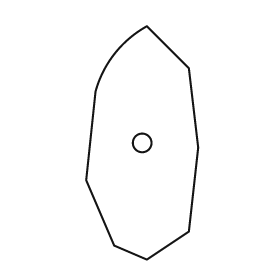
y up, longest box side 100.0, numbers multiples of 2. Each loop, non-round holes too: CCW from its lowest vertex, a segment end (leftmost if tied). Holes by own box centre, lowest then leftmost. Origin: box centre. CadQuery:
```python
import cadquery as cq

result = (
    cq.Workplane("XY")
    .moveTo(2.0, -50.0)
    .lineTo(20.0, -38.0)
    .lineTo(24.0, -2.0)
    .lineTo(20.0, 32.0)
    .lineTo(2.0, 50.0)
    .threePointArc((-12.0, 38.0), (-20.0, 22.0))
    .lineTo(-24.0, -16.0)
    .lineTo(-12.0, -44.0)
    .close()
    .moveTo(0.0, 0.0)
    .circle(4.0)
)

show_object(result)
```